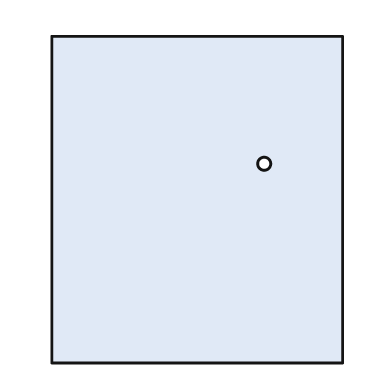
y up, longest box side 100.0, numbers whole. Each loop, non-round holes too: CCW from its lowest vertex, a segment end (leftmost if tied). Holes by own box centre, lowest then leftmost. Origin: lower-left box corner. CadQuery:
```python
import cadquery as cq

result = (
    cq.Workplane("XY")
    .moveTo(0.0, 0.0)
    .lineTo(89.0, 0.0)
    .lineTo(89.0, 100.0)
    .lineTo(0.0, 100.0)
    .close()
    .moveTo(65.0, 61.0)
    .circle(2.0)
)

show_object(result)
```